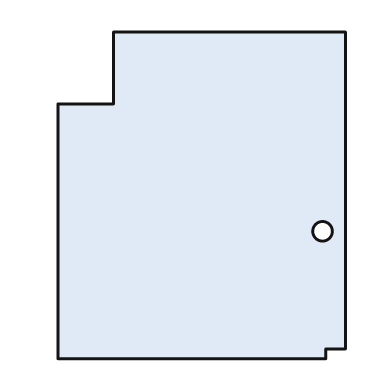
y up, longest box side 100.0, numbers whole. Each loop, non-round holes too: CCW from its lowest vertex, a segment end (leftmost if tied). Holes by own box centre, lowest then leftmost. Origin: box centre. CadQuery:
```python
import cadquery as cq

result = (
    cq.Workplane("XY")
    .moveTo(-44.0, -50.0)
    .lineTo(38.0, -50.0)
    .lineTo(38.0, -47.0)
    .lineTo(44.0, -47.0)
    .lineTo(44.0, 50.0)
    .lineTo(-27.0, 50.0)
    .lineTo(-27.0, 28.0)
    .lineTo(-44.0, 28.0)
    .close()
    .moveTo(37.0, -11.0)
    .circle(3.0)
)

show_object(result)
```